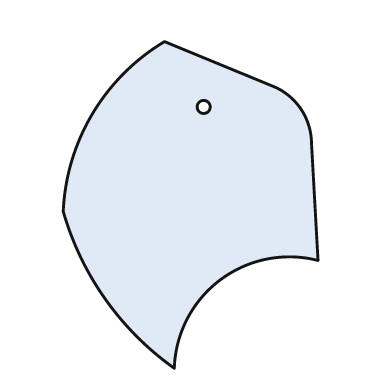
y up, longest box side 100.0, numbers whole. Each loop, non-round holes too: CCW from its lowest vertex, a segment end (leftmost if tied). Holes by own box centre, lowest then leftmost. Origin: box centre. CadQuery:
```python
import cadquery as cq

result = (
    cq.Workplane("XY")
    .moveTo(-5.0, -50.0)
    .threePointArc((9.0, -23.0), (39.0, -17.0))
    .lineTo(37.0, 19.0)
    .threePointArc((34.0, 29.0), (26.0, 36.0))
    .lineTo(-8.0, 50.0)
    .threePointArc((-30.0, 28.0), (-39.0, -2.0))
    .threePointArc((-26.0, -29.0), (-5.0, -50.0))
    .close()
    .moveTo(4.0, 30.0)
    .circle(2.0)
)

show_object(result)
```